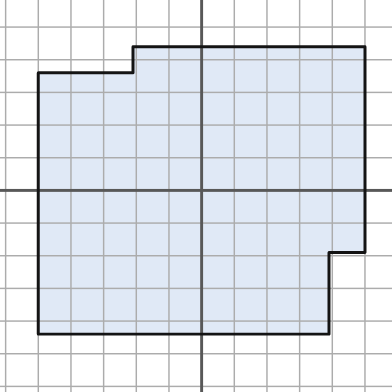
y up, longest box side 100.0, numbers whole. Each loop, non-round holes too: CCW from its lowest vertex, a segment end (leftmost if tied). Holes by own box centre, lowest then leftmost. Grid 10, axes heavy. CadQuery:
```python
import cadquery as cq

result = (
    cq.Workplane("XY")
    .moveTo(-50.0, -44.0)
    .lineTo(39.0, -44.0)
    .lineTo(39.0, -19.0)
    .lineTo(50.0, -19.0)
    .lineTo(50.0, 44.0)
    .lineTo(-21.0, 44.0)
    .lineTo(-21.0, 36.0)
    .lineTo(-50.0, 36.0)
    .close()
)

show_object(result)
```